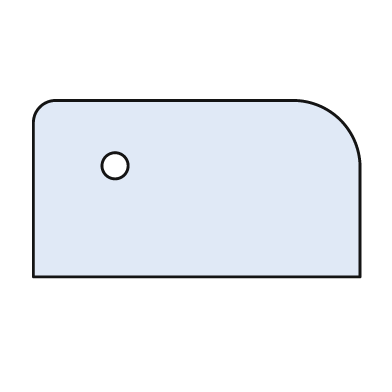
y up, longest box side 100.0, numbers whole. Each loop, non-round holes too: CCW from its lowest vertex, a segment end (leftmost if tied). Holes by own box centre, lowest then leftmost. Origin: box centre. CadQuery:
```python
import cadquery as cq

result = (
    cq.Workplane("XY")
    .moveTo(-50.0, -27.0)
    .lineTo(50.0, -27.0)
    .lineTo(50.0, 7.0)
    .threePointArc((44.0, 21.0), (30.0, 27.0))
    .lineTo(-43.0, 27.0)
    .threePointArc((-48.0, 25.0), (-50.0, 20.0))
    .close()
    .moveTo(-25.0, 7.0)
    .circle(4.0)
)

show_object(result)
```